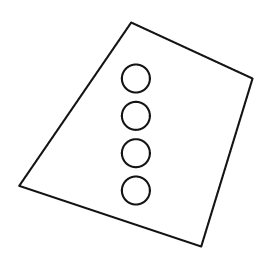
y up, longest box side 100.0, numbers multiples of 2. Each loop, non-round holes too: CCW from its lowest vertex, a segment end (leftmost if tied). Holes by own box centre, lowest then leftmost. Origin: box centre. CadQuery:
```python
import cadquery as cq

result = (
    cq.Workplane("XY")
    .moveTo(28.0, -48.0)
    .lineTo(50.0, 24.0)
    .lineTo(-2.0, 48.0)
    .lineTo(-50.0, -22.0)
    .close()
    .moveTo(0.0, -24.0)
    .circle(6.0)
    .moveTo(0.0, -8.0)
    .circle(6.0)
    .moveTo(0.0, 8.0)
    .circle(6.0)
    .moveTo(0.0, 24.0)
    .circle(6.0)
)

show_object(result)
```